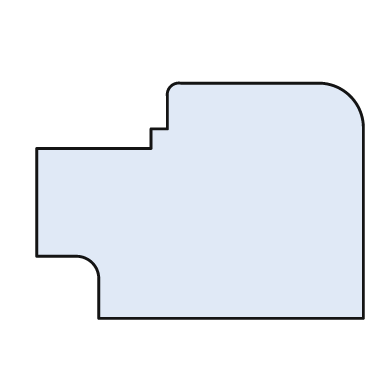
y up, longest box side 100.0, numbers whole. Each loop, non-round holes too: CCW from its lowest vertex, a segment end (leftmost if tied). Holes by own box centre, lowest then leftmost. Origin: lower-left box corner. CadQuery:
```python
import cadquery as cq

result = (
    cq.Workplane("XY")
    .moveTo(19.0, 0.0)
    .lineTo(100.0, 0.0)
    .lineTo(100.0, 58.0)
    .threePointArc((96.0, 68.0), (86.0, 72.0))
    .lineTo(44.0, 72.0)
    .threePointArc((41.0, 71.0), (40.0, 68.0))
    .lineTo(40.0, 58.0)
    .lineTo(35.0, 58.0)
    .lineTo(35.0, 52.0)
    .lineTo(0.0, 52.0)
    .lineTo(0.0, 19.0)
    .lineTo(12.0, 19.0)
    .threePointArc((17.0, 17.0), (19.0, 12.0))
    .close()
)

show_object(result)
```